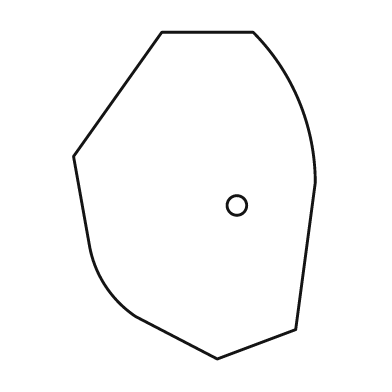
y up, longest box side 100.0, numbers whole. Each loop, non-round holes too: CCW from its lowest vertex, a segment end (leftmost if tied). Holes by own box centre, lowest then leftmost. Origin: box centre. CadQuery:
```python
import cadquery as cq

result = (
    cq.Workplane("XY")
    .moveTo(7.0, -50.0)
    .lineTo(31.0, -41.0)
    .lineTo(37.0, 4.0)
    .threePointArc((32.0, 29.0), (18.0, 50.0))
    .lineTo(-10.0, 50.0)
    .lineTo(-37.0, 12.0)
    .lineTo(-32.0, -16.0)
    .threePointArc((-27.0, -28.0), (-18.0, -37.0))
    .close()
    .moveTo(13.0, -3.0)
    .circle(3.0)
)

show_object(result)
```